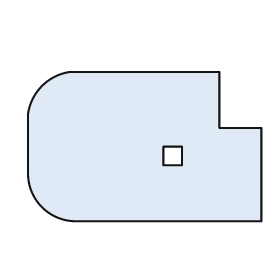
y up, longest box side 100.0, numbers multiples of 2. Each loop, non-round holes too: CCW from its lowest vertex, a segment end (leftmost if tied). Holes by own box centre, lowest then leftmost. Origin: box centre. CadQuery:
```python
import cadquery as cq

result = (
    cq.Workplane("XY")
    .moveTo(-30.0, -32.0)
    .lineTo(50.0, -32.0)
    .lineTo(50.0, 8.0)
    .lineTo(32.0, 8.0)
    .lineTo(32.0, 32.0)
    .lineTo(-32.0, 32.0)
    .threePointArc((-44.0, 26.0), (-50.0, 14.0))
    .lineTo(-50.0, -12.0)
    .threePointArc((-44.0, -26.0), (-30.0, -32.0))
    .close()
    .moveTo(8.0, -8.0)
    .lineTo(16.0, -8.0)
    .lineTo(16.0, 0.0)
    .lineTo(8.0, 0.0)
    .close()
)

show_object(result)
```